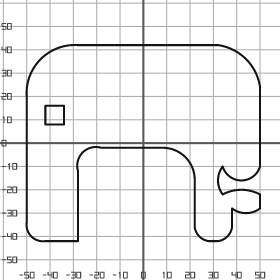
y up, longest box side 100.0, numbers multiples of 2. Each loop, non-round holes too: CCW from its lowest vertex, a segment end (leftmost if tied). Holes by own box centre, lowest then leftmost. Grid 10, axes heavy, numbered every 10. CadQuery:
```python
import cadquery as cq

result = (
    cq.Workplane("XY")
    .moveTo(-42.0, -42.0)
    .lineTo(-28.0, -42.0)
    .lineTo(-28.0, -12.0)
    .threePointArc((-26.0, -4.0), (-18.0, -2.0))
    .lineTo(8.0, -2.0)
    .threePointArc((18.0, -6.0), (22.0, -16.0))
    .lineTo(22.0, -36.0)
    .threePointArc((24.0, -40.0), (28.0, -42.0))
    .lineTo(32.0, -42.0)
    .threePointArc((36.0, -40.0), (38.0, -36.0))
    .lineTo(38.0, -28.0)
    .threePointArc((44.0, -30.0), (50.0, -28.0))
    .lineTo(50.0, -22.0)
    .threePointArc((42.0, -20.0), (34.0, -22.0))
    .threePointArc((32.0, -16.0), (34.0, -10.0))
    .threePointArc((42.0, -16.0), (50.0, -10.0))
    .lineTo(50.0, 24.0)
    .threePointArc((44.0, 36.0), (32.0, 42.0))
    .lineTo(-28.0, 42.0)
    .threePointArc((-44.0, 36.0), (-50.0, 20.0))
    .lineTo(-50.0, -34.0)
    .threePointArc((-48.0, -40.0), (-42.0, -42.0))
    .close()
    .moveTo(-42.0, 8.0)
    .lineTo(-34.0, 8.0)
    .lineTo(-34.0, 16.0)
    .lineTo(-42.0, 16.0)
    .close()
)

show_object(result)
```